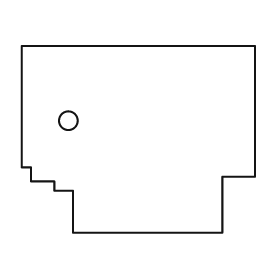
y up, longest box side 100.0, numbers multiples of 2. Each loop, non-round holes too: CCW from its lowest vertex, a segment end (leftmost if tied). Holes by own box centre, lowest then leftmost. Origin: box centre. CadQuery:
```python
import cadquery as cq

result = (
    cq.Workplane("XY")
    .moveTo(-28.0, -40.0)
    .lineTo(36.0, -40.0)
    .lineTo(36.0, -16.0)
    .lineTo(50.0, -16.0)
    .lineTo(50.0, 40.0)
    .lineTo(-50.0, 40.0)
    .lineTo(-50.0, -12.0)
    .lineTo(-46.0, -12.0)
    .lineTo(-46.0, -18.0)
    .lineTo(-36.0, -18.0)
    .lineTo(-36.0, -22.0)
    .lineTo(-28.0, -22.0)
    .close()
    .moveTo(-30.0, 8.0)
    .circle(4.0)
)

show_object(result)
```